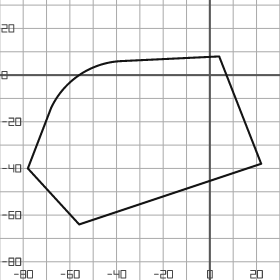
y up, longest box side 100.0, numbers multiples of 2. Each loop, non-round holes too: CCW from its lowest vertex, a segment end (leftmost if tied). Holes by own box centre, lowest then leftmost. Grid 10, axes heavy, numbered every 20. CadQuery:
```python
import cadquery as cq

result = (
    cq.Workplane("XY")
    .moveTo(-56.0, -64.0)
    .lineTo(22.0, -38.0)
    .lineTo(4.0, 8.0)
    .lineTo(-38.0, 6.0)
    .threePointArc((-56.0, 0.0), (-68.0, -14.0))
    .lineTo(-78.0, -40.0)
    .close()
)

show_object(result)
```